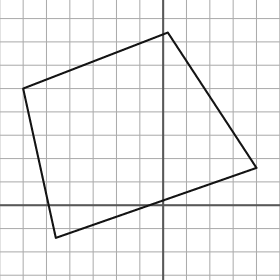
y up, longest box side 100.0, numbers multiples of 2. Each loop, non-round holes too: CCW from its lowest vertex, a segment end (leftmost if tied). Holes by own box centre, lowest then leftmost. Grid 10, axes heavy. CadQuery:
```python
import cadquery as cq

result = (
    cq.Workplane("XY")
    .moveTo(-46.0, -14.0)
    .lineTo(40.0, 16.0)
    .lineTo(2.0, 74.0)
    .lineTo(-60.0, 50.0)
    .close()
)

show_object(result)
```